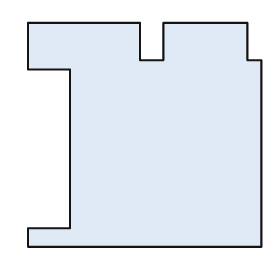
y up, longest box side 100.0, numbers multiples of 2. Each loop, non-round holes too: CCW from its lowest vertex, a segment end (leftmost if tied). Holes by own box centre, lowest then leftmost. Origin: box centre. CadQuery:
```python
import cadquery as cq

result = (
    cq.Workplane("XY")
    .moveTo(-50.0, -48.0)
    .lineTo(50.0, -48.0)
    .lineTo(50.0, 32.0)
    .lineTo(44.0, 32.0)
    .lineTo(44.0, 48.0)
    .lineTo(8.0, 48.0)
    .lineTo(8.0, 32.0)
    .lineTo(-2.0, 32.0)
    .lineTo(-2.0, 48.0)
    .lineTo(-50.0, 48.0)
    .lineTo(-50.0, 28.0)
    .lineTo(-32.0, 28.0)
    .lineTo(-32.0, -40.0)
    .lineTo(-50.0, -40.0)
    .close()
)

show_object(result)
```